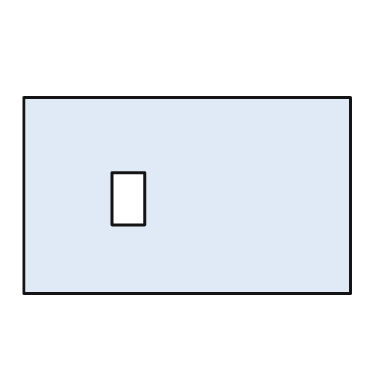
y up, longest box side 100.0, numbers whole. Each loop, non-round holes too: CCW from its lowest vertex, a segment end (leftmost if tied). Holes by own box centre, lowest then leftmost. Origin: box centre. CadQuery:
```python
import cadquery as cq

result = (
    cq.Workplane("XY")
    .moveTo(-50.0, -30.0)
    .lineTo(50.0, -30.0)
    .lineTo(50.0, 30.0)
    .lineTo(-50.0, 30.0)
    .close()
    .moveTo(-23.0, -9.0)
    .lineTo(-13.0, -9.0)
    .lineTo(-13.0, 7.0)
    .lineTo(-23.0, 7.0)
    .close()
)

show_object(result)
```